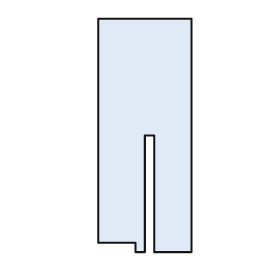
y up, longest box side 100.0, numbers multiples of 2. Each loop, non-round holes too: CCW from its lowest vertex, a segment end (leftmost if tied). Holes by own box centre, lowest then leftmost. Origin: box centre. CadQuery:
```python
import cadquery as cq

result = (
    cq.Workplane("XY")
    .moveTo(-4.0, -50.0)
    .lineTo(0.0, -50.0)
    .lineTo(0.0, 0.0)
    .lineTo(4.0, 0.0)
    .lineTo(4.0, -50.0)
    .lineTo(20.0, -50.0)
    .lineTo(20.0, 50.0)
    .lineTo(-20.0, 50.0)
    .lineTo(-20.0, -46.0)
    .lineTo(-4.0, -46.0)
    .close()
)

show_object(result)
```